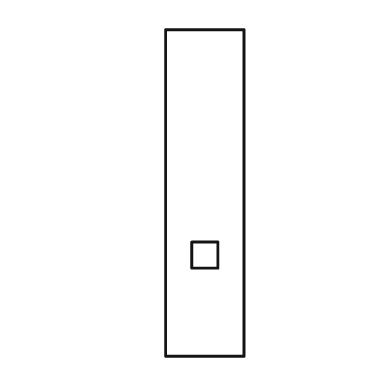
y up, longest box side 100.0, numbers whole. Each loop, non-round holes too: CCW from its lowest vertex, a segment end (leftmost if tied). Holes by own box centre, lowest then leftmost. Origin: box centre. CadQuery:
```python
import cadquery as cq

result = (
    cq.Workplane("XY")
    .moveTo(-12.0, -50.0)
    .lineTo(12.0, -50.0)
    .lineTo(12.0, 50.0)
    .lineTo(-12.0, 50.0)
    .close()
    .moveTo(-4.0, -23.0)
    .lineTo(4.0, -23.0)
    .lineTo(4.0, -15.0)
    .lineTo(-4.0, -15.0)
    .close()
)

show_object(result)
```